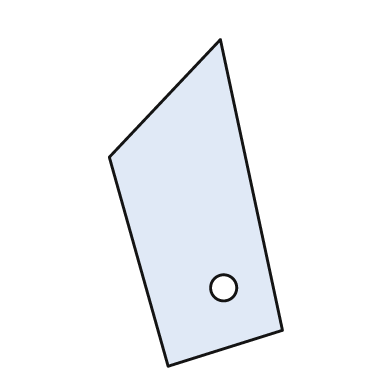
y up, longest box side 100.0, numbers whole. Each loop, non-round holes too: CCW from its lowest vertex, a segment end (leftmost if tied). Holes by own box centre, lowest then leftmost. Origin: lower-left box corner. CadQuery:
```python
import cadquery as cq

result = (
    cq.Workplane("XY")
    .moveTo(18.0, 0.0)
    .lineTo(53.0, 11.0)
    .lineTo(34.0, 100.0)
    .lineTo(0.0, 64.0)
    .close()
    .moveTo(35.0, 24.0)
    .circle(4.0)
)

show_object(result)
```